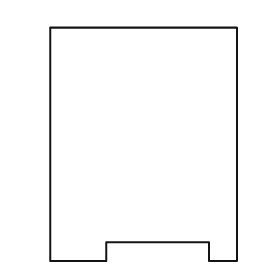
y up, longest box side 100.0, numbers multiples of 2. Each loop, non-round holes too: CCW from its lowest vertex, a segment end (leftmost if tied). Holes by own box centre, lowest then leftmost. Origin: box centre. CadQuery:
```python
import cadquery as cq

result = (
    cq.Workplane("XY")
    .moveTo(-40.0, -50.0)
    .lineTo(-16.0, -50.0)
    .lineTo(-16.0, -42.0)
    .lineTo(28.0, -42.0)
    .lineTo(28.0, -50.0)
    .lineTo(40.0, -50.0)
    .lineTo(40.0, 50.0)
    .lineTo(-40.0, 50.0)
    .close()
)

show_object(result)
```